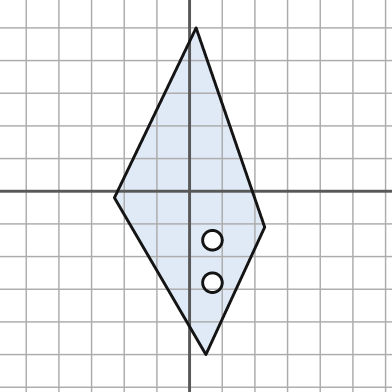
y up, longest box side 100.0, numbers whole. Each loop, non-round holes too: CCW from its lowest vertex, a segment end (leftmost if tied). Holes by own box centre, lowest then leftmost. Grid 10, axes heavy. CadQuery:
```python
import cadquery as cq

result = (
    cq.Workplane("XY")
    .moveTo(5.0, -50.0)
    .lineTo(23.0, -11.0)
    .lineTo(2.0, 50.0)
    .lineTo(-23.0, -2.0)
    .close()
    .moveTo(7.0, -28.0)
    .circle(3.0)
    .moveTo(7.0, -15.0)
    .circle(3.0)
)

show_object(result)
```